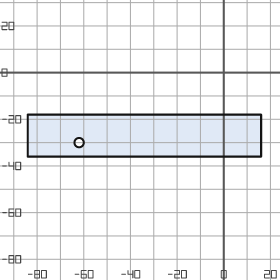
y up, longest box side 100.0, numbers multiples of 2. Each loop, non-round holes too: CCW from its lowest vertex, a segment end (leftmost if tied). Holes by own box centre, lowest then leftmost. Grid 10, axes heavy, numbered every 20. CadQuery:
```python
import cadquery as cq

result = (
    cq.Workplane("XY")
    .moveTo(-84.0, -36.0)
    .lineTo(16.0, -36.0)
    .lineTo(16.0, -18.0)
    .lineTo(-84.0, -18.0)
    .close()
    .moveTo(-62.0, -30.0)
    .circle(2.0)
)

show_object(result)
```